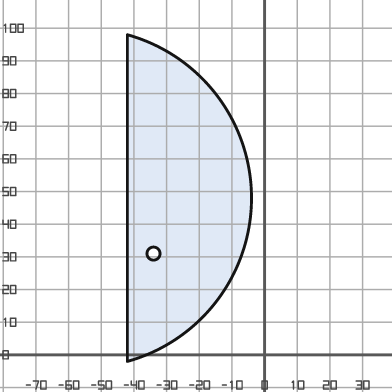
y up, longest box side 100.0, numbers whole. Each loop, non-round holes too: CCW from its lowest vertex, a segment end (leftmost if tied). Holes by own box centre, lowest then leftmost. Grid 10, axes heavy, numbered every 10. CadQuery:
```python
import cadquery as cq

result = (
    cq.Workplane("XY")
    .moveTo(-42.0, -2.0)
    .threePointArc((-4.0, 48.0), (-42.0, 98.0))
    .close()
    .moveTo(-34.0, 31.0)
    .circle(2.0)
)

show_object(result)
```